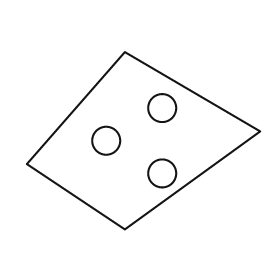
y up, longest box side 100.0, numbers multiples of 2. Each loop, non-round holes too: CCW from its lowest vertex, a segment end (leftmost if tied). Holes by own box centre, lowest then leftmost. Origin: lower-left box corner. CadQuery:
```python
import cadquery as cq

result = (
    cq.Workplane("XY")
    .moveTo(42.0, 0.0)
    .lineTo(100.0, 42.0)
    .lineTo(42.0, 76.0)
    .lineTo(0.0, 28.0)
    .close()
    .moveTo(58.0, 24.0)
    .circle(6.0)
    .moveTo(34.0, 38.0)
    .circle(6.0)
    .moveTo(58.0, 52.0)
    .circle(6.0)
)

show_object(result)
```